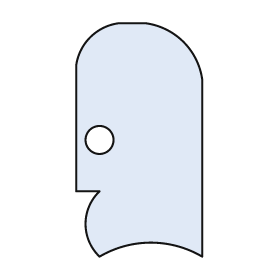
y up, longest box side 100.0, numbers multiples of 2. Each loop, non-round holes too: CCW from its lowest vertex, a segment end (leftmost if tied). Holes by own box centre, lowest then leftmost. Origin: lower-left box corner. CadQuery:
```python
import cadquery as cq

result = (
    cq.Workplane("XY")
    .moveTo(10.0, 0.0)
    .threePointArc((32.0, 6.0), (54.0, 0.0))
    .lineTo(54.0, 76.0)
    .threePointArc((46.0, 92.0), (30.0, 100.0))
    .lineTo(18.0, 100.0)
    .threePointArc((6.0, 94.0), (0.0, 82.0))
    .lineTo(0.0, 28.0)
    .lineTo(10.0, 28.0)
    .threePointArc((4.0, 14.0), (10.0, 0.0))
    .close()
    .moveTo(10.0, 50.0)
    .circle(6.0)
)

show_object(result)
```